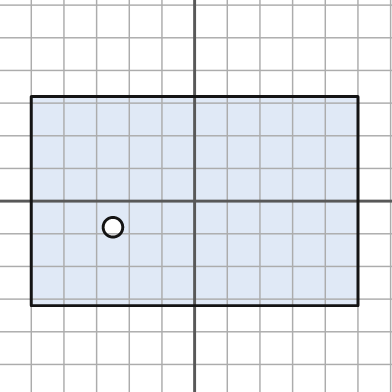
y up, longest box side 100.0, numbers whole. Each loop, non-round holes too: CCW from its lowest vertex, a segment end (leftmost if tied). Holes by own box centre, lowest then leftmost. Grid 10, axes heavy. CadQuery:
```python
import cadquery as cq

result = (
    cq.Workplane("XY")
    .moveTo(-50.0, -32.0)
    .lineTo(50.0, -32.0)
    .lineTo(50.0, 32.0)
    .lineTo(-50.0, 32.0)
    .close()
    .moveTo(-25.0, -8.0)
    .circle(3.0)
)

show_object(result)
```